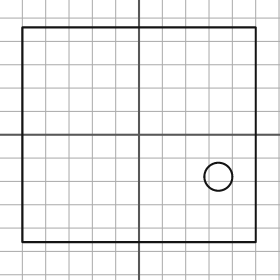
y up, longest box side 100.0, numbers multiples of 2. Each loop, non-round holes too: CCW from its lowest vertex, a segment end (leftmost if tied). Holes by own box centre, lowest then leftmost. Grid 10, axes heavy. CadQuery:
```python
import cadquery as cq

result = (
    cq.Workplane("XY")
    .moveTo(-50.0, -46.0)
    .lineTo(50.0, -46.0)
    .lineTo(50.0, 46.0)
    .lineTo(-50.0, 46.0)
    .close()
    .moveTo(34.0, -18.0)
    .circle(6.0)
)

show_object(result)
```